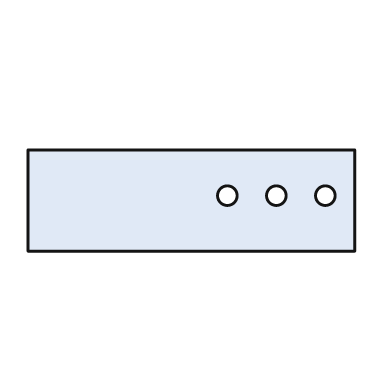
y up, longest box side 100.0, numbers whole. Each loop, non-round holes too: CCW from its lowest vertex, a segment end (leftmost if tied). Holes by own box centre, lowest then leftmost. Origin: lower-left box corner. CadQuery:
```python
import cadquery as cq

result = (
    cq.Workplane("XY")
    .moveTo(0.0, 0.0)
    .lineTo(100.0, 0.0)
    .lineTo(100.0, 31.0)
    .lineTo(0.0, 31.0)
    .close()
    .moveTo(61.0, 17.0)
    .circle(3.0)
    .moveTo(76.0, 17.0)
    .circle(3.0)
    .moveTo(91.0, 17.0)
    .circle(3.0)
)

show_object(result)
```